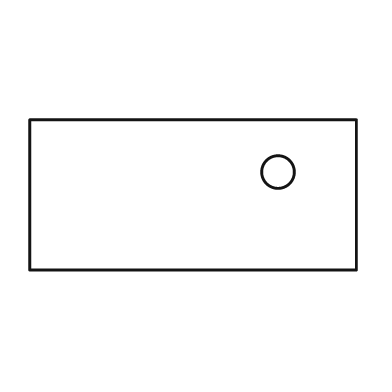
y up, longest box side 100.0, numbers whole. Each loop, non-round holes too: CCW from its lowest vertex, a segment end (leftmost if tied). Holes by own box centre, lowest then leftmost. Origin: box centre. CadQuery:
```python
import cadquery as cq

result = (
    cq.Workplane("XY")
    .moveTo(-50.0, -23.0)
    .lineTo(50.0, -23.0)
    .lineTo(50.0, 23.0)
    .lineTo(-50.0, 23.0)
    .close()
    .moveTo(26.0, 7.0)
    .circle(5.0)
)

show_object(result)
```